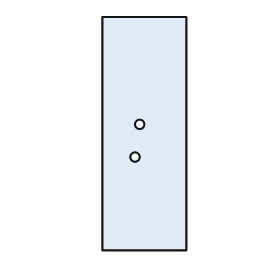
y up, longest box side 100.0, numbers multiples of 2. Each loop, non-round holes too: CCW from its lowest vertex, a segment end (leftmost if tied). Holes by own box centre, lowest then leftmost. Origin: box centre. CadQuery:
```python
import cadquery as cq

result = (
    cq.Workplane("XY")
    .moveTo(-18.0, -50.0)
    .lineTo(18.0, -50.0)
    .lineTo(18.0, 50.0)
    .lineTo(-18.0, 50.0)
    .close()
    .moveTo(-4.0, -10.0)
    .circle(2.0)
    .moveTo(-2.0, 4.0)
    .circle(2.0)
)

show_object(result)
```